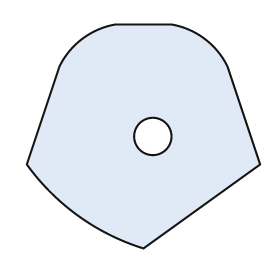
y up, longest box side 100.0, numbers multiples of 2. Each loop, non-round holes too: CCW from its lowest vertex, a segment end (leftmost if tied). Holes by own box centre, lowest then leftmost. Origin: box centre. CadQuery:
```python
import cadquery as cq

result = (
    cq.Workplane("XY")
    .moveTo(0.0, -48.0)
    .lineTo(50.0, -12.0)
    .lineTo(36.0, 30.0)
    .threePointArc((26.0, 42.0), (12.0, 48.0))
    .lineTo(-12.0, 48.0)
    .threePointArc((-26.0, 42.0), (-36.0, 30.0))
    .lineTo(-50.0, -12.0)
    .threePointArc((-28.0, -34.0), (0.0, -48.0))
    .close()
    .moveTo(4.0, 0.0)
    .circle(8.0)
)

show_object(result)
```